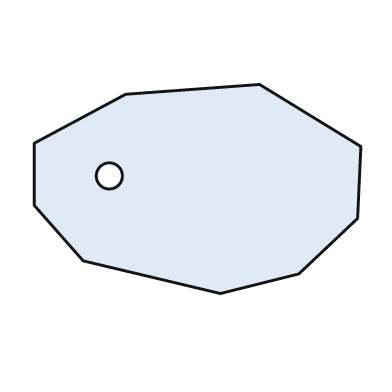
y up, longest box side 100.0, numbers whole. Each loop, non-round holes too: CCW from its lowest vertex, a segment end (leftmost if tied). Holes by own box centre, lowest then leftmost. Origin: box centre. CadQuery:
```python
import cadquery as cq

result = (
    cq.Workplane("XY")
    .moveTo(7.0, -32.0)
    .lineTo(31.0, -26.0)
    .lineTo(49.0, -9.0)
    .lineTo(50.0, 13.0)
    .lineTo(19.0, 32.0)
    .lineTo(-22.0, 29.0)
    .lineTo(-50.0, 14.0)
    .lineTo(-50.0, -5.0)
    .lineTo(-35.0, -22.0)
    .close()
    .moveTo(-27.0, 4.0)
    .circle(4.0)
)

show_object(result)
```